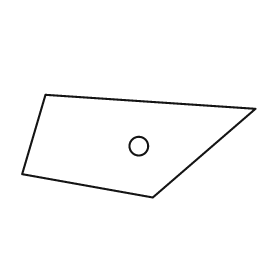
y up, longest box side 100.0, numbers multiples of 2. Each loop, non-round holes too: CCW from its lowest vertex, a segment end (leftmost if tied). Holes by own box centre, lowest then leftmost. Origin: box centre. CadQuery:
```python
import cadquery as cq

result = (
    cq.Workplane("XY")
    .moveTo(6.0, -22.0)
    .lineTo(50.0, 16.0)
    .lineTo(-40.0, 22.0)
    .lineTo(-50.0, -12.0)
    .close()
    .moveTo(0.0, 0.0)
    .circle(4.0)
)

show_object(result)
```